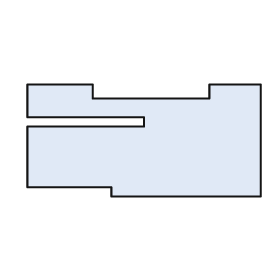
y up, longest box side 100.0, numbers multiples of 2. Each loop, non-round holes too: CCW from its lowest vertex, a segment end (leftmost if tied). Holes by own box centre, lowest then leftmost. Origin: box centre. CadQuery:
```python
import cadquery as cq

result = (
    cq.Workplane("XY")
    .moveTo(-14.0, -24.0)
    .lineTo(50.0, -24.0)
    .lineTo(50.0, 24.0)
    .lineTo(28.0, 24.0)
    .lineTo(28.0, 18.0)
    .lineTo(-22.0, 18.0)
    .lineTo(-22.0, 24.0)
    .lineTo(-50.0, 24.0)
    .lineTo(-50.0, 10.0)
    .lineTo(0.0, 10.0)
    .lineTo(0.0, 6.0)
    .lineTo(-50.0, 6.0)
    .lineTo(-50.0, -20.0)
    .lineTo(-14.0, -20.0)
    .close()
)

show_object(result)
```